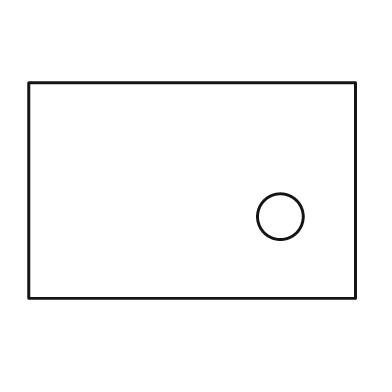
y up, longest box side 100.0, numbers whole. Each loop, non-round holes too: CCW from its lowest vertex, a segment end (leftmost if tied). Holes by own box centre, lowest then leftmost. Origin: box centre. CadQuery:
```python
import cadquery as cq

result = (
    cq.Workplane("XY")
    .moveTo(-50.0, -33.0)
    .lineTo(50.0, -33.0)
    .lineTo(50.0, 33.0)
    .lineTo(-50.0, 33.0)
    .close()
    .moveTo(27.0, -8.0)
    .circle(7.0)
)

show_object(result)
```